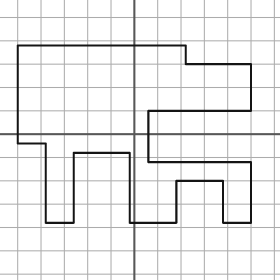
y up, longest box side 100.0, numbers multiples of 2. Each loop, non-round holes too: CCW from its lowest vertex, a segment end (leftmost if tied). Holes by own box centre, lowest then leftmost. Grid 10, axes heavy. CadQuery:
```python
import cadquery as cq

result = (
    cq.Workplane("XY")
    .moveTo(-38.0, -38.0)
    .lineTo(-26.0, -38.0)
    .lineTo(-26.0, -8.0)
    .lineTo(-2.0, -8.0)
    .lineTo(-2.0, -38.0)
    .lineTo(18.0, -38.0)
    .lineTo(18.0, -20.0)
    .lineTo(38.0, -20.0)
    .lineTo(38.0, -38.0)
    .lineTo(50.0, -38.0)
    .lineTo(50.0, -12.0)
    .lineTo(6.0, -12.0)
    .lineTo(6.0, 10.0)
    .lineTo(50.0, 10.0)
    .lineTo(50.0, 30.0)
    .lineTo(22.0, 30.0)
    .lineTo(22.0, 38.0)
    .lineTo(-50.0, 38.0)
    .lineTo(-50.0, -4.0)
    .lineTo(-38.0, -4.0)
    .close()
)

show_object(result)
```